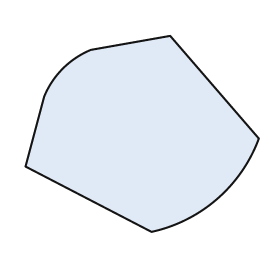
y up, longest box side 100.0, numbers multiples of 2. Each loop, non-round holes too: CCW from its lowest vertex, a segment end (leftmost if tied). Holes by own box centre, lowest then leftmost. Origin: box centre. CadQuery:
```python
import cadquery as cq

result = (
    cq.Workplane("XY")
    .moveTo(4.0, -42.0)
    .threePointArc((32.0, -28.0), (50.0, -2.0))
    .lineTo(12.0, 42.0)
    .lineTo(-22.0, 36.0)
    .threePointArc((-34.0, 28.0), (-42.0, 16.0))
    .lineTo(-50.0, -14.0)
    .close()
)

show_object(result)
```